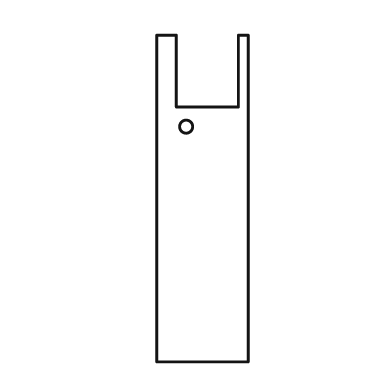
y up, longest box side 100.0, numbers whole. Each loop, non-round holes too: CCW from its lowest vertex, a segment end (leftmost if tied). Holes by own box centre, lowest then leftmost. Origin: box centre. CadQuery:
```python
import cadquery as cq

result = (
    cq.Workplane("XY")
    .moveTo(-14.0, -50.0)
    .lineTo(14.0, -50.0)
    .lineTo(14.0, 50.0)
    .lineTo(11.0, 50.0)
    .lineTo(11.0, 28.0)
    .lineTo(-8.0, 28.0)
    .lineTo(-8.0, 50.0)
    .lineTo(-14.0, 50.0)
    .close()
    .moveTo(-5.0, 22.0)
    .circle(2.0)
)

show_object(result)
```